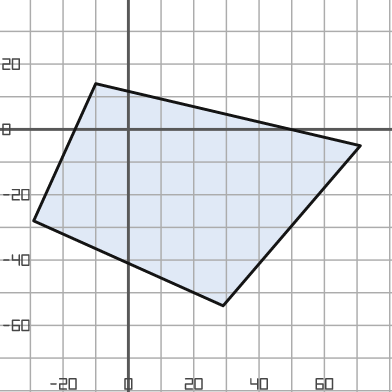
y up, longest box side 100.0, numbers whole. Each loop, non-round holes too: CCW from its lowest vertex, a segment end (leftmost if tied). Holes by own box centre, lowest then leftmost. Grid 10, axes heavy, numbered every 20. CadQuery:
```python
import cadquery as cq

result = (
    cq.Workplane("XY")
    .moveTo(29.0, -54.0)
    .lineTo(71.0, -5.0)
    .lineTo(-10.0, 14.0)
    .lineTo(-29.0, -28.0)
    .close()
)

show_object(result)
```